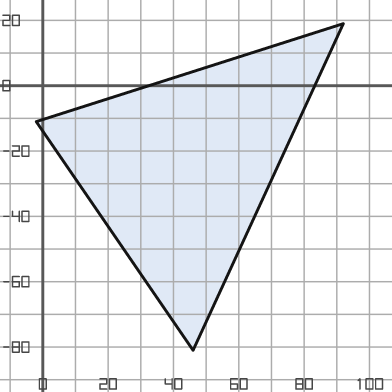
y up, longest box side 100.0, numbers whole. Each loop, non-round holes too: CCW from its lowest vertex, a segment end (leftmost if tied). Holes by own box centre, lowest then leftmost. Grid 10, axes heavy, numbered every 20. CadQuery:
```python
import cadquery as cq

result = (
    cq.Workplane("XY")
    .moveTo(46.0, -81.0)
    .lineTo(92.0, 19.0)
    .lineTo(-2.0, -11.0)
    .close()
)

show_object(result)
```